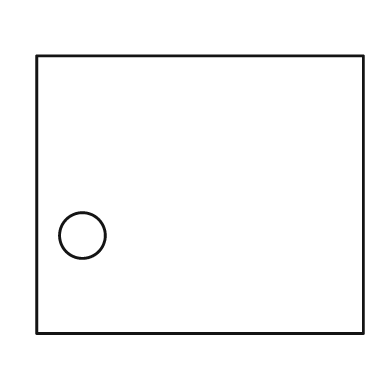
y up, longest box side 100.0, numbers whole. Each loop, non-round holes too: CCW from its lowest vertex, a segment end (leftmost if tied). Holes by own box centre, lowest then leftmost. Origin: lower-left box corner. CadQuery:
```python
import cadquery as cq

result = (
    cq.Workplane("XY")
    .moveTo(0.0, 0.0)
    .lineTo(100.0, 0.0)
    .lineTo(100.0, 85.0)
    .lineTo(0.0, 85.0)
    .close()
    .moveTo(14.0, 30.0)
    .circle(7.0)
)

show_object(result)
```